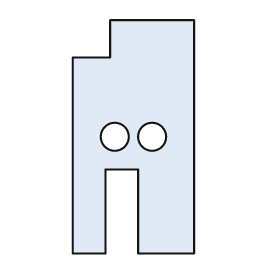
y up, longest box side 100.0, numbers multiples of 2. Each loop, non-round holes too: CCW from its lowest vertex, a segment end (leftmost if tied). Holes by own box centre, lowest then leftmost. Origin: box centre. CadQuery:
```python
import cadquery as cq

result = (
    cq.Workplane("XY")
    .moveTo(-26.0, -50.0)
    .lineTo(-12.0, -50.0)
    .lineTo(-12.0, -14.0)
    .lineTo(2.0, -14.0)
    .lineTo(2.0, -50.0)
    .lineTo(26.0, -50.0)
    .lineTo(26.0, 50.0)
    .lineTo(-10.0, 50.0)
    .lineTo(-10.0, 34.0)
    .lineTo(-26.0, 34.0)
    .close()
    .moveTo(-8.0, 0.0)
    .circle(6.0)
    .moveTo(8.0, 0.0)
    .circle(6.0)
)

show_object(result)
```